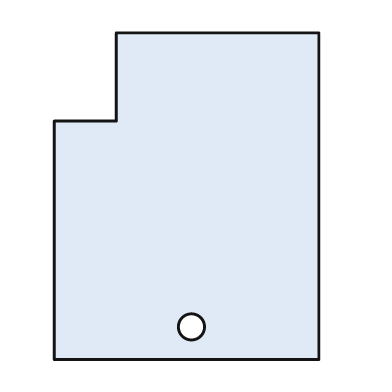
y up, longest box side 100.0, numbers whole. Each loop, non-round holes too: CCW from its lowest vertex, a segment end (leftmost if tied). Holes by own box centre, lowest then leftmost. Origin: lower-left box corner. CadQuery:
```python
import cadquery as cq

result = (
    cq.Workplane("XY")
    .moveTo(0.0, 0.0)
    .lineTo(81.0, 0.0)
    .lineTo(81.0, 100.0)
    .lineTo(19.0, 100.0)
    .lineTo(19.0, 73.0)
    .lineTo(0.0, 73.0)
    .close()
    .moveTo(42.0, 10.0)
    .circle(4.0)
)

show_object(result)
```